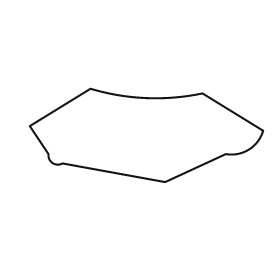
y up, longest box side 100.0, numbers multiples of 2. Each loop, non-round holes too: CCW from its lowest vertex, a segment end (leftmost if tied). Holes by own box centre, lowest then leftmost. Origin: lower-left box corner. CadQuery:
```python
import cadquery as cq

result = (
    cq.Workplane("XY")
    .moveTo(58.0, 0.0)
    .lineTo(84.0, 12.0)
    .threePointArc((94.0, 14.0), (100.0, 22.0))
    .lineTo(74.0, 38.0)
    .threePointArc((50.0, 36.0), (26.0, 40.0))
    .lineTo(0.0, 24.0)
    .lineTo(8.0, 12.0)
    .threePointArc((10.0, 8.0), (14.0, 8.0))
    .close()
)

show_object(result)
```